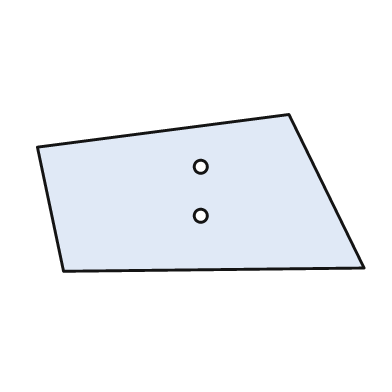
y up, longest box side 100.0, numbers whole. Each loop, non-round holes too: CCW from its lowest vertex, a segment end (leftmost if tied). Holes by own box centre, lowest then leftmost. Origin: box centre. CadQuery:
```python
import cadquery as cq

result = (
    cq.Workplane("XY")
    .moveTo(-42.0, -24.0)
    .lineTo(50.0, -23.0)
    .lineTo(27.0, 24.0)
    .lineTo(-50.0, 14.0)
    .close()
    .moveTo(0.0, -7.0)
    .circle(2.0)
    .moveTo(0.0, 8.0)
    .circle(2.0)
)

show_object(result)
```